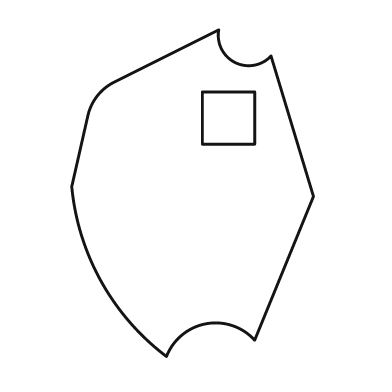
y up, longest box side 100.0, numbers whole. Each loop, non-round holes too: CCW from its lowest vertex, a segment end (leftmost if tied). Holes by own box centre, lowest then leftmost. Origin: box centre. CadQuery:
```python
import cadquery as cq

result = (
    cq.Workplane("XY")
    .moveTo(-8.0, -50.0)
    .threePointArc((4.0, -40.0), (19.0, -45.0))
    .lineTo(37.0, -1.0)
    .lineTo(24.0, 42.0)
    .threePointArc((13.0, 40.0), (8.0, 50.0))
    .lineTo(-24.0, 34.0)
    .threePointArc((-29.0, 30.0), (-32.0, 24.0))
    .lineTo(-37.0, 2.0)
    .threePointArc((-28.0, -27.0), (-8.0, -50.0))
    .close()
    .moveTo(3.0, 15.0)
    .lineTo(19.0, 15.0)
    .lineTo(19.0, 31.0)
    .lineTo(3.0, 31.0)
    .close()
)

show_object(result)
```